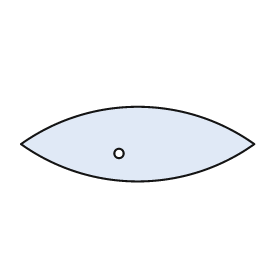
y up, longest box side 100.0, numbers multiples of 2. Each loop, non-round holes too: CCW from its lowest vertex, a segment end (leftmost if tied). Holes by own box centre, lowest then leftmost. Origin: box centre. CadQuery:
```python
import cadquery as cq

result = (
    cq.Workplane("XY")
    .moveTo(-50.0, 0.0)
    .threePointArc((0.0, -16.0), (50.0, 0.0))
    .threePointArc((0.0, 16.0), (-50.0, 0.0))
    .close()
    .moveTo(-8.0, -4.0)
    .circle(2.0)
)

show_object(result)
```